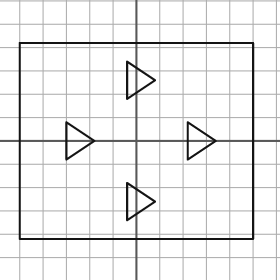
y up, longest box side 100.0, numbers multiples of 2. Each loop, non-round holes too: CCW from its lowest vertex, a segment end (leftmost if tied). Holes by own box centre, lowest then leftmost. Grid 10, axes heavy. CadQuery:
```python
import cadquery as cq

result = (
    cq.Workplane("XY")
    .moveTo(-50.0, -42.0)
    .lineTo(50.0, -42.0)
    .lineTo(50.0, 42.0)
    .lineTo(-50.0, 42.0)
    .close()
    .moveTo(-4.0, -34.0)
    .lineTo(8.0, -26.0)
    .lineTo(-4.0, -18.0)
    .close()
    .moveTo(-30.0, -8.0)
    .lineTo(-18.0, 0.0)
    .lineTo(-30.0, 8.0)
    .close()
    .moveTo(22.0, -8.0)
    .lineTo(34.0, 0.0)
    .lineTo(22.0, 8.0)
    .close()
    .moveTo(-4.0, 18.0)
    .lineTo(8.0, 26.0)
    .lineTo(-4.0, 34.0)
    .close()
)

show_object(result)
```